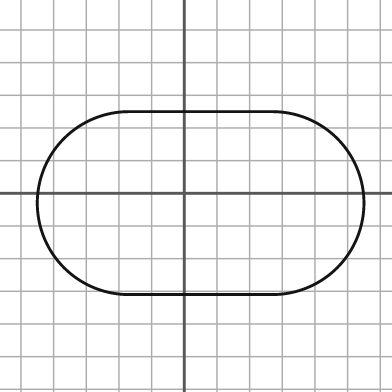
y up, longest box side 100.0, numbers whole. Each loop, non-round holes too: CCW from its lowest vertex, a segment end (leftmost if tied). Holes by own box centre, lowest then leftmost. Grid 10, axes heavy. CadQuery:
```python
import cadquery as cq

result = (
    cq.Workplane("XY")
    .moveTo(-17.0, -31.0)
    .lineTo(27.0, -31.0)
    .threePointArc((55.0, -3.0), (27.0, 25.0))
    .lineTo(-17.0, 25.0)
    .threePointArc((-45.0, -3.0), (-17.0, -31.0))
    .close()
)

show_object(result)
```